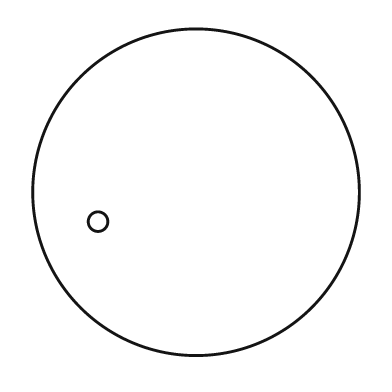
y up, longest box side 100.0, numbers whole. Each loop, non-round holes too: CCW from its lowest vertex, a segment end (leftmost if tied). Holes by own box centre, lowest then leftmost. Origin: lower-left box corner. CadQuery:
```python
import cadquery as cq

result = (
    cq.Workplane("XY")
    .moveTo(50.0, 50.0)
    .circle(50.0)
    .moveTo(20.0, 41.0)
    .circle(3.0)
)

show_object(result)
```